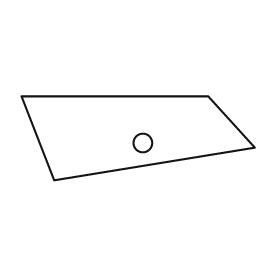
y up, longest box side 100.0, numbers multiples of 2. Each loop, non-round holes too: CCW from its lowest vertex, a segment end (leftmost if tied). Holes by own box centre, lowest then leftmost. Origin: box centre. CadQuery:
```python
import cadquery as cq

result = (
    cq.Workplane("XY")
    .moveTo(-36.0, -18.0)
    .lineTo(50.0, -4.0)
    .lineTo(30.0, 18.0)
    .lineTo(-50.0, 18.0)
    .close()
    .moveTo(2.0, -2.0)
    .circle(4.0)
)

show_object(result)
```